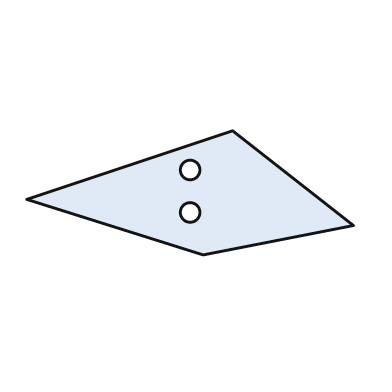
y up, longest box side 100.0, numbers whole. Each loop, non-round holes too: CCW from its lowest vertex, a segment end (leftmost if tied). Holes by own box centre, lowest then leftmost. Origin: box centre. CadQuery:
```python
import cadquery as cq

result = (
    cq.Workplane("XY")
    .moveTo(4.0, -19.0)
    .lineTo(50.0, -10.0)
    .lineTo(13.0, 19.0)
    .lineTo(-50.0, -2.0)
    .close()
    .moveTo(0.0, -6.0)
    .circle(3.0)
    .moveTo(0.0, 7.0)
    .circle(3.0)
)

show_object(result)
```